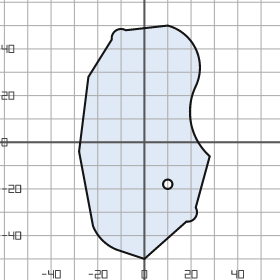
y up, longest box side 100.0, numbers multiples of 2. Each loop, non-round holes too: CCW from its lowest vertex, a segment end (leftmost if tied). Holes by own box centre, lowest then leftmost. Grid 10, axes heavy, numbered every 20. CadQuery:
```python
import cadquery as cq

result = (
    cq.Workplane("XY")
    .moveTo(0.0, -50.0)
    .lineTo(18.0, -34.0)
    .threePointArc((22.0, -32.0), (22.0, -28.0))
    .lineTo(28.0, -6.0)
    .threePointArc((20.0, 8.0), (22.0, 24.0))
    .threePointArc((22.0, 40.0), (10.0, 50.0))
    .lineTo(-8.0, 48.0)
    .threePointArc((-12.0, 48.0), (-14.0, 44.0))
    .lineTo(-24.0, 28.0)
    .lineTo(-28.0, -4.0)
    .lineTo(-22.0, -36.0)
    .threePointArc((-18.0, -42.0), (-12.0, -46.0))
    .close()
    .moveTo(10.0, -18.0)
    .circle(2.0)
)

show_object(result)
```